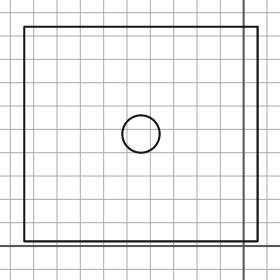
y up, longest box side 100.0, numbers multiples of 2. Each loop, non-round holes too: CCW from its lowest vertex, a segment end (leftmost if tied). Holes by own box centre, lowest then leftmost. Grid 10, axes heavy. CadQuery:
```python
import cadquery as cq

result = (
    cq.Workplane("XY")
    .moveTo(-94.0, 2.0)
    .lineTo(6.0, 2.0)
    .lineTo(6.0, 94.0)
    .lineTo(-94.0, 94.0)
    .close()
    .moveTo(-44.0, 48.0)
    .circle(8.0)
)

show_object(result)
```